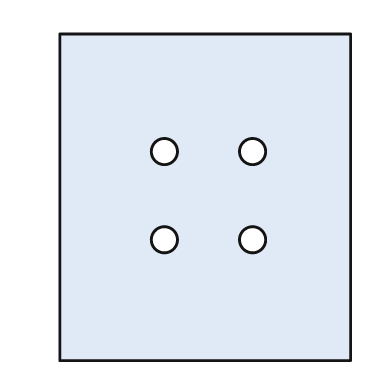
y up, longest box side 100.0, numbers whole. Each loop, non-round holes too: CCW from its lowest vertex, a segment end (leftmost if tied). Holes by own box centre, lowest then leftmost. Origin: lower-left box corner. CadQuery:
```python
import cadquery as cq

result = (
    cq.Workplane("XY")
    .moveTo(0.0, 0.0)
    .lineTo(89.0, 0.0)
    .lineTo(89.0, 100.0)
    .lineTo(0.0, 100.0)
    .close()
    .moveTo(32.0, 37.0)
    .circle(4.0)
    .moveTo(59.0, 37.0)
    .circle(4.0)
    .moveTo(32.0, 64.0)
    .circle(4.0)
    .moveTo(59.0, 64.0)
    .circle(4.0)
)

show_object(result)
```